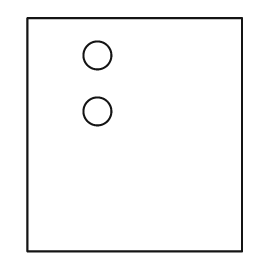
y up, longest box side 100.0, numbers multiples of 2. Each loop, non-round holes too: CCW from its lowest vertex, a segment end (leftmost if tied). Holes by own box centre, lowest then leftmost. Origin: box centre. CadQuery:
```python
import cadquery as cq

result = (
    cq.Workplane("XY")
    .moveTo(-46.0, -50.0)
    .lineTo(46.0, -50.0)
    .lineTo(46.0, 50.0)
    .lineTo(-46.0, 50.0)
    .close()
    .moveTo(-16.0, 10.0)
    .circle(6.0)
    .moveTo(-16.0, 34.0)
    .circle(6.0)
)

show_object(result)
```